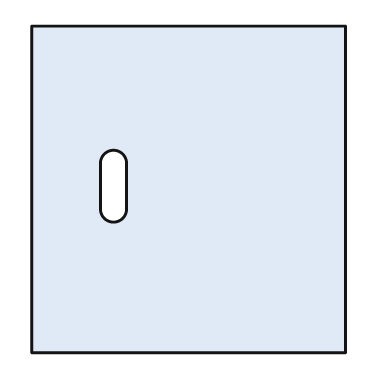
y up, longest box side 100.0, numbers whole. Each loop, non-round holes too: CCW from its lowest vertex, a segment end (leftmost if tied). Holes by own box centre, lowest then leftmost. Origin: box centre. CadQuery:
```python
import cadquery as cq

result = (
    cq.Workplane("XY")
    .moveTo(-48.0, -50.0)
    .lineTo(48.0, -50.0)
    .lineTo(48.0, 50.0)
    .lineTo(-48.0, 50.0)
    .close()
    .moveTo(-27.0, -6.0)
    .threePointArc((-23.0, -10.0), (-19.0, -6.0))
    .lineTo(-19.0, 8.0)
    .threePointArc((-23.0, 12.0), (-27.0, 8.0))
    .close()
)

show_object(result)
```